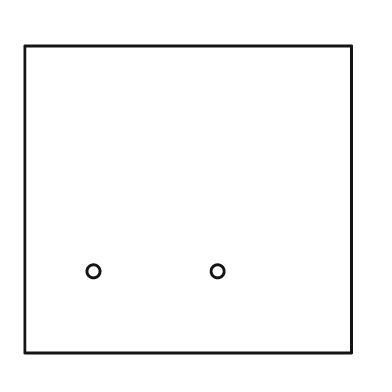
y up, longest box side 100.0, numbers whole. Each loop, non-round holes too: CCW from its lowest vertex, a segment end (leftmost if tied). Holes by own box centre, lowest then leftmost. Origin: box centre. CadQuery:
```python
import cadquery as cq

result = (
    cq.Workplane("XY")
    .moveTo(-50.0, -47.0)
    .lineTo(50.0, -47.0)
    .lineTo(50.0, 47.0)
    .lineTo(-50.0, 47.0)
    .close()
    .moveTo(-29.0, -22.0)
    .circle(2.0)
    .moveTo(9.0, -22.0)
    .circle(2.0)
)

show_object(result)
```